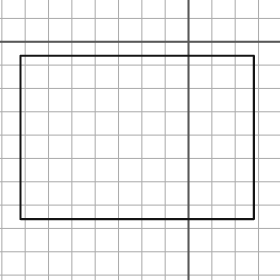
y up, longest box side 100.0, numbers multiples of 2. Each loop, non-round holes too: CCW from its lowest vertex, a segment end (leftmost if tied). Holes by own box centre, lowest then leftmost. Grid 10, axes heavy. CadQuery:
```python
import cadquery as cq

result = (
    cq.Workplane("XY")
    .moveTo(-72.0, -76.0)
    .lineTo(28.0, -76.0)
    .lineTo(28.0, -6.0)
    .lineTo(-72.0, -6.0)
    .close()
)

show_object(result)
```